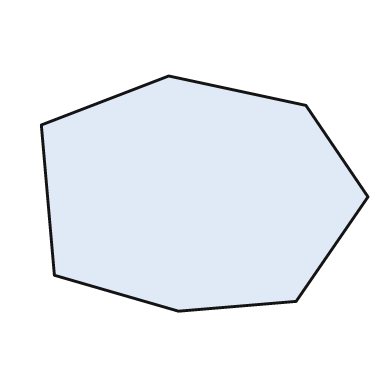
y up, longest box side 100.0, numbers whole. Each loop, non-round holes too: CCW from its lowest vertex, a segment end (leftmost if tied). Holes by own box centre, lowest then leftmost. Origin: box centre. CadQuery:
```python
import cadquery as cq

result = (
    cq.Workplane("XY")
    .moveTo(-8.0, -36.0)
    .lineTo(28.0, -33.0)
    .lineTo(50.0, -1.0)
    .lineTo(31.0, 27.0)
    .lineTo(-11.0, 36.0)
    .lineTo(-50.0, 21.0)
    .lineTo(-46.0, -25.0)
    .close()
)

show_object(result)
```